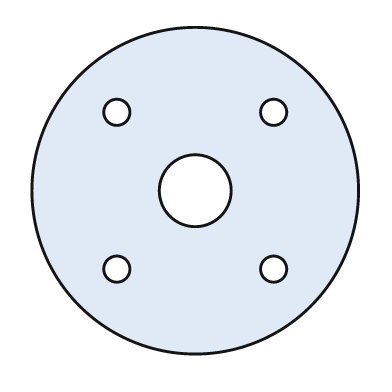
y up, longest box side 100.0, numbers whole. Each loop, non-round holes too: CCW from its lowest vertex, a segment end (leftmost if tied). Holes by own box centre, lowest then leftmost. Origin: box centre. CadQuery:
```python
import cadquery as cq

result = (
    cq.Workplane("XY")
    .moveTo(0.0, 0.0)
    .circle(50.0)
    .moveTo(-24.0, -24.0)
    .circle(4.0)
    .moveTo(24.0, -24.0)
    .circle(4.0)
    .moveTo(0.0, 0.0)
    .circle(11.0)
    .moveTo(-24.0, 24.0)
    .circle(4.0)
    .moveTo(24.0, 24.0)
    .circle(4.0)
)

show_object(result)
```